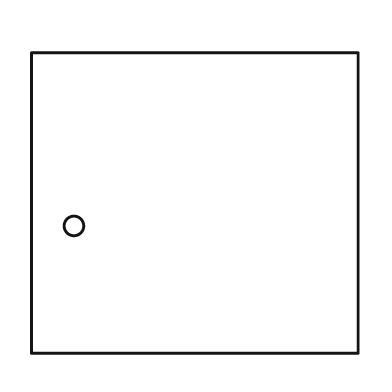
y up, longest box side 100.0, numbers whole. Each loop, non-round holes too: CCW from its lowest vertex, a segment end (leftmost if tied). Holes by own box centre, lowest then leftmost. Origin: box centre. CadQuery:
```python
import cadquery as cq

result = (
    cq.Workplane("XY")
    .moveTo(-50.0, -46.0)
    .lineTo(50.0, -46.0)
    .lineTo(50.0, 46.0)
    .lineTo(-50.0, 46.0)
    .close()
    .moveTo(-37.0, -7.0)
    .circle(3.0)
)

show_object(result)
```